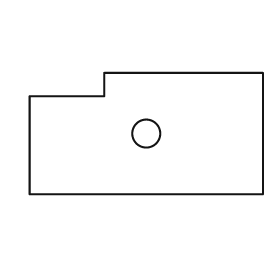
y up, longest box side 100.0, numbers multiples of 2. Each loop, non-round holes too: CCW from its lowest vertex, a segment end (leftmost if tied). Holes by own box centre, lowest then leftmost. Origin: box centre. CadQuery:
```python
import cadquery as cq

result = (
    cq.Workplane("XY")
    .moveTo(-50.0, -26.0)
    .lineTo(50.0, -26.0)
    .lineTo(50.0, 26.0)
    .lineTo(-18.0, 26.0)
    .lineTo(-18.0, 16.0)
    .lineTo(-50.0, 16.0)
    .close()
    .moveTo(0.0, 0.0)
    .circle(6.0)
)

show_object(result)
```